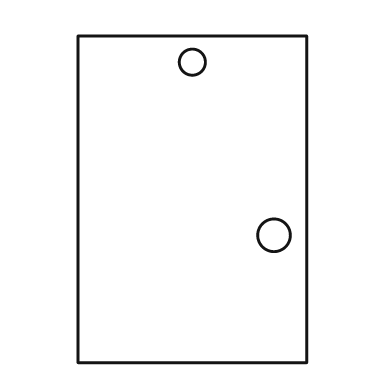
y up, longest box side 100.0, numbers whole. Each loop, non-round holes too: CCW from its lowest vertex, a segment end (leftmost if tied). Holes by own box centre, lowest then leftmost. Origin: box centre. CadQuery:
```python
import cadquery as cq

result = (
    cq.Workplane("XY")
    .moveTo(-35.0, -50.0)
    .lineTo(35.0, -50.0)
    .lineTo(35.0, 50.0)
    .lineTo(-35.0, 50.0)
    .close()
    .moveTo(25.0, -11.0)
    .circle(5.0)
    .moveTo(0.0, 42.0)
    .circle(4.0)
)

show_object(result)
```